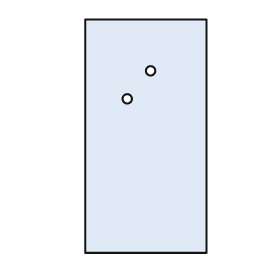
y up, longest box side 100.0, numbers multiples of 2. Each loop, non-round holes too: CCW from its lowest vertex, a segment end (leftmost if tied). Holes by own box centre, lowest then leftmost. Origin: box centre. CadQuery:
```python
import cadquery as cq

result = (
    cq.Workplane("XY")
    .moveTo(-26.0, -50.0)
    .lineTo(26.0, -50.0)
    .lineTo(26.0, 50.0)
    .lineTo(-26.0, 50.0)
    .close()
    .moveTo(-8.0, 16.0)
    .circle(2.0)
    .moveTo(2.0, 28.0)
    .circle(2.0)
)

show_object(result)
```